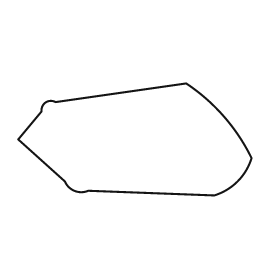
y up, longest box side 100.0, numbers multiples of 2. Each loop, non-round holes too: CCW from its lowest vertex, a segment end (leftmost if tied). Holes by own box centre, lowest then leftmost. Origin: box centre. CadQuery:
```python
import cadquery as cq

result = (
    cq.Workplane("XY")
    .moveTo(34.0, -24.0)
    .threePointArc((44.0, -18.0), (50.0, -8.0))
    .threePointArc((38.0, 10.0), (22.0, 24.0))
    .lineTo(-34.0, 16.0)
    .threePointArc((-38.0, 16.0), (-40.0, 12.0))
    .lineTo(-50.0, 0.0)
    .lineTo(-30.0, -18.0)
    .threePointArc((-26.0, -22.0), (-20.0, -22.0))
    .close()
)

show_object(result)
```